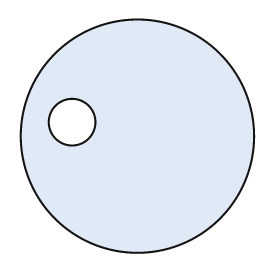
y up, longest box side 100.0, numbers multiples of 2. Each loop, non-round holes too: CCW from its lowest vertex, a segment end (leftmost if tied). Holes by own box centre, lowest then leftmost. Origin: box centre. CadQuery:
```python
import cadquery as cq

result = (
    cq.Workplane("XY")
    .moveTo(0.0, 0.0)
    .circle(50.0)
    .moveTo(-28.0, 6.0)
    .circle(10.0)
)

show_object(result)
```